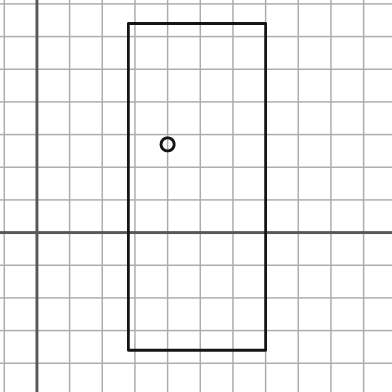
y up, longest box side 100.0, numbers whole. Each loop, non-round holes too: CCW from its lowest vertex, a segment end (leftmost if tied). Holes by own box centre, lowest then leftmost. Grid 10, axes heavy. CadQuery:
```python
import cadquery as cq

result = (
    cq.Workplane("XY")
    .moveTo(28.0, -36.0)
    .lineTo(70.0, -36.0)
    .lineTo(70.0, 64.0)
    .lineTo(28.0, 64.0)
    .close()
    .moveTo(40.0, 27.0)
    .circle(2.0)
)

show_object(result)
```